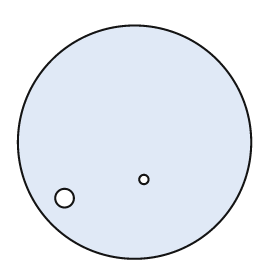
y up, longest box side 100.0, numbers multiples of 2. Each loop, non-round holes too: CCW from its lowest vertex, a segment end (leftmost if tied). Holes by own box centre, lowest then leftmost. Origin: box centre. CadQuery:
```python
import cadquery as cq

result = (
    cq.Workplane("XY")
    .moveTo(0.0, 0.0)
    .circle(50.0)
    .moveTo(-30.0, -24.0)
    .circle(4.0)
    .moveTo(4.0, -16.0)
    .circle(2.0)
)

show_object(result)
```